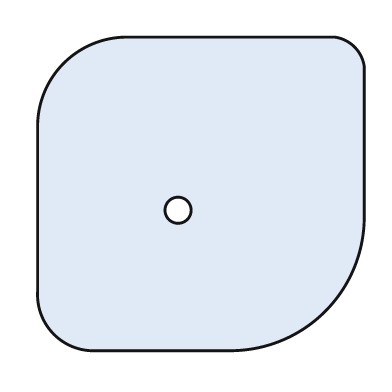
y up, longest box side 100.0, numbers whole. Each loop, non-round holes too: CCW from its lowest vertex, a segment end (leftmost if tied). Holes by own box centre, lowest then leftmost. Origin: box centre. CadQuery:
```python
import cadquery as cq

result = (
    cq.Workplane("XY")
    .moveTo(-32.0, -48.0)
    .lineTo(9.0, -48.0)
    .threePointArc((38.0, -36.0), (50.0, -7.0))
    .lineTo(50.0, 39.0)
    .threePointArc((47.0, 45.0), (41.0, 48.0))
    .lineTo(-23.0, 48.0)
    .threePointArc((-42.0, 40.0), (-50.0, 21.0))
    .lineTo(-50.0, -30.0)
    .threePointArc((-45.0, -43.0), (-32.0, -48.0))
    .close()
    .moveTo(-7.0, -5.0)
    .circle(4.0)
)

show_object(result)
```